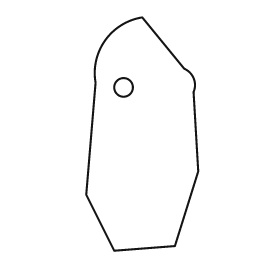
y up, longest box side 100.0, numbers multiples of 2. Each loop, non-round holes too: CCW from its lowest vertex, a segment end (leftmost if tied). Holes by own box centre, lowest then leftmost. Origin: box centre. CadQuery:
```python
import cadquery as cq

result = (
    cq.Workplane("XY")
    .moveTo(-12.0, -50.0)
    .lineTo(14.0, -48.0)
    .lineTo(24.0, -16.0)
    .lineTo(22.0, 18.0)
    .threePointArc((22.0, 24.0), (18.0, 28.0))
    .lineTo(0.0, 50.0)
    .threePointArc((-16.0, 40.0), (-20.0, 22.0))
    .lineTo(-24.0, -26.0)
    .close()
    .moveTo(-8.0, 20.0)
    .circle(4.0)
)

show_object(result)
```